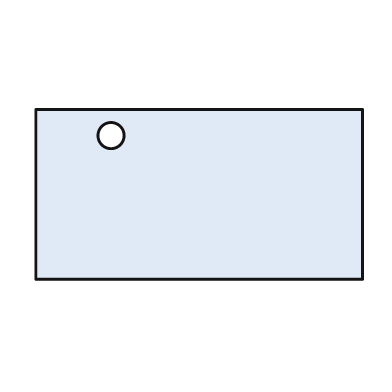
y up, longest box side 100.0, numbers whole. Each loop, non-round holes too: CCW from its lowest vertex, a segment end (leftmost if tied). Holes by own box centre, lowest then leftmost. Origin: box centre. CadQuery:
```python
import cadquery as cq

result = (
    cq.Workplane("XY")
    .moveTo(-50.0, -26.0)
    .lineTo(50.0, -26.0)
    .lineTo(50.0, 26.0)
    .lineTo(-50.0, 26.0)
    .close()
    .moveTo(-27.0, 18.0)
    .circle(4.0)
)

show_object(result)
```